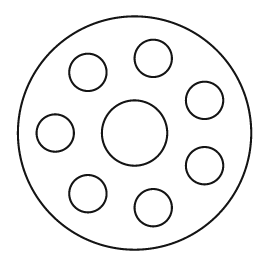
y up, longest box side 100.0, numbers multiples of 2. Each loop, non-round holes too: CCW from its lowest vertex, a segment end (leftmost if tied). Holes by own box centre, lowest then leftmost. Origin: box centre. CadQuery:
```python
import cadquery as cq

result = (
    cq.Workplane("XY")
    .moveTo(0.0, 0.0)
    .circle(50.0)
    .moveTo(8.0, -32.0)
    .circle(8.0)
    .moveTo(-20.0, -26.0)
    .circle(8.0)
    .moveTo(30.0, -14.0)
    .circle(8.0)
    .moveTo(-34.0, 0.0)
    .circle(8.0)
    .moveTo(0.0, 0.0)
    .circle(14.0)
    .moveTo(30.0, 14.0)
    .circle(8.0)
    .moveTo(-20.0, 26.0)
    .circle(8.0)
    .moveTo(8.0, 32.0)
    .circle(8.0)
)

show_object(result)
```